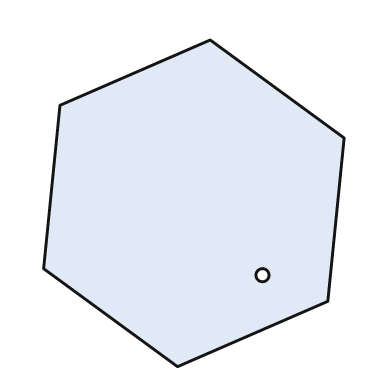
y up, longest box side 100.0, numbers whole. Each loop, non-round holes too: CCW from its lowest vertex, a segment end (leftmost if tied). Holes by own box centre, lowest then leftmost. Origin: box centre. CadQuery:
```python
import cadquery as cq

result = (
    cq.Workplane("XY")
    .moveTo(-5.0, -50.0)
    .lineTo(41.0, -30.0)
    .lineTo(46.0, 20.0)
    .lineTo(5.0, 50.0)
    .lineTo(-41.0, 30.0)
    .lineTo(-46.0, -20.0)
    .close()
    .moveTo(21.0, -22.0)
    .circle(2.0)
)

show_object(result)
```